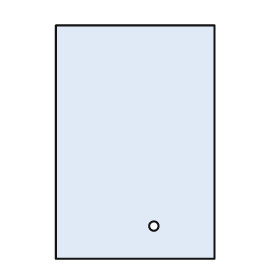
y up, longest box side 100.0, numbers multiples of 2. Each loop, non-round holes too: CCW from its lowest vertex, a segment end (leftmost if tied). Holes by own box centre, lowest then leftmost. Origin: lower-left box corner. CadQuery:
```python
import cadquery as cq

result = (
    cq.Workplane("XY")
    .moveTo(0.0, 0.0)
    .lineTo(68.0, 0.0)
    .lineTo(68.0, 100.0)
    .lineTo(0.0, 100.0)
    .close()
    .moveTo(42.0, 14.0)
    .circle(2.0)
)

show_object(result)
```